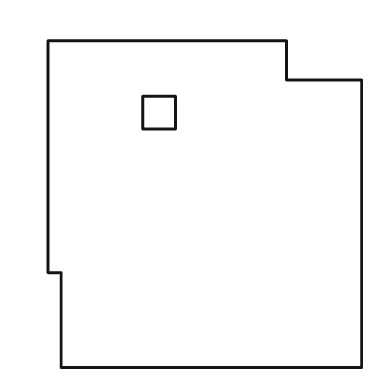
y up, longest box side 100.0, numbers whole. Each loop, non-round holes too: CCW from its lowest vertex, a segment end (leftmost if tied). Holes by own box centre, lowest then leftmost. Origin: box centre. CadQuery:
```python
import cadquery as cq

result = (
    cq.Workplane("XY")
    .moveTo(-44.0, -50.0)
    .lineTo(48.0, -50.0)
    .lineTo(48.0, 38.0)
    .lineTo(25.0, 38.0)
    .lineTo(25.0, 50.0)
    .lineTo(-48.0, 50.0)
    .lineTo(-48.0, -21.0)
    .lineTo(-44.0, -21.0)
    .close()
    .moveTo(-19.0, 23.0)
    .lineTo(-9.0, 23.0)
    .lineTo(-9.0, 33.0)
    .lineTo(-19.0, 33.0)
    .close()
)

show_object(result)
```